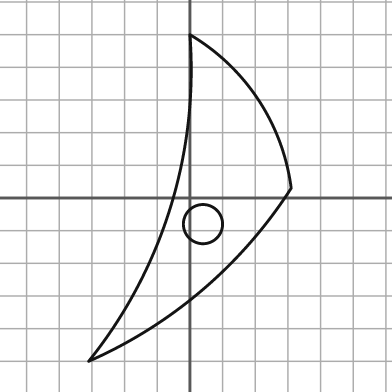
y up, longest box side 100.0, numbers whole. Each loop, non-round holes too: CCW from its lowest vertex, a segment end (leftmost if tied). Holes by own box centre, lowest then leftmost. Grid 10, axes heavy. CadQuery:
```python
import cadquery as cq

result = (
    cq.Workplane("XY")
    .moveTo(-31.0, -50.0)
    .threePointArc((4.0, -28.0), (31.0, 3.0))
    .threePointArc((21.0, 30.0), (0.0, 50.0))
    .threePointArc((-6.0, -3.0), (-31.0, -50.0))
    .close()
    .moveTo(4.0, -8.0)
    .circle(6.0)
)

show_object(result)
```